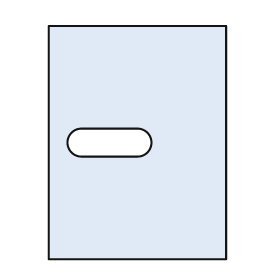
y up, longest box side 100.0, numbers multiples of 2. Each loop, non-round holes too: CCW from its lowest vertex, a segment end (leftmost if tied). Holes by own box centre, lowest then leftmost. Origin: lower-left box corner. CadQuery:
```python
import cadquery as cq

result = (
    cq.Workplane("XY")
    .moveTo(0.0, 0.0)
    .lineTo(76.0, 0.0)
    .lineTo(76.0, 100.0)
    .lineTo(0.0, 100.0)
    .close()
    .moveTo(14.0, 44.0)
    .lineTo(38.0, 44.0)
    .threePointArc((44.0, 50.0), (38.0, 56.0))
    .lineTo(14.0, 56.0)
    .threePointArc((8.0, 50.0), (14.0, 44.0))
    .close()
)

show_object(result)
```